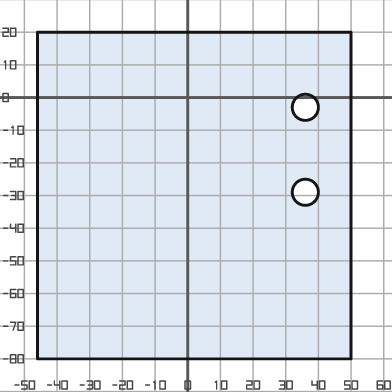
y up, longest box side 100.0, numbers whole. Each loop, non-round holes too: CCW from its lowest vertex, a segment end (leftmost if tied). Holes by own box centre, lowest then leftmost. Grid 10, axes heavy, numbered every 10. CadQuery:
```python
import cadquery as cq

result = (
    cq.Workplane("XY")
    .moveTo(-46.0, -80.0)
    .lineTo(50.0, -80.0)
    .lineTo(50.0, 20.0)
    .lineTo(-46.0, 20.0)
    .close()
    .moveTo(36.0, -29.0)
    .circle(4.0)
    .moveTo(36.0, -3.0)
    .circle(4.0)
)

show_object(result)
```